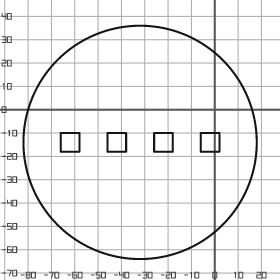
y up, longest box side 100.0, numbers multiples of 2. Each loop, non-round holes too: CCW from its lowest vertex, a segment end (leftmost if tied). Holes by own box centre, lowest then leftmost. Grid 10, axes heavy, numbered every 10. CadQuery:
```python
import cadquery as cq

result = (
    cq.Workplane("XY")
    .moveTo(-32.0, -14.0)
    .circle(50.0)
    .moveTo(-66.0, -18.0)
    .lineTo(-58.0, -18.0)
    .lineTo(-58.0, -10.0)
    .lineTo(-66.0, -10.0)
    .close()
    .moveTo(-46.0, -18.0)
    .lineTo(-38.0, -18.0)
    .lineTo(-38.0, -10.0)
    .lineTo(-46.0, -10.0)
    .close()
    .moveTo(-26.0, -18.0)
    .lineTo(-18.0, -18.0)
    .lineTo(-18.0, -10.0)
    .lineTo(-26.0, -10.0)
    .close()
    .moveTo(-6.0, -18.0)
    .lineTo(2.0, -18.0)
    .lineTo(2.0, -10.0)
    .lineTo(-6.0, -10.0)
    .close()
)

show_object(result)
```